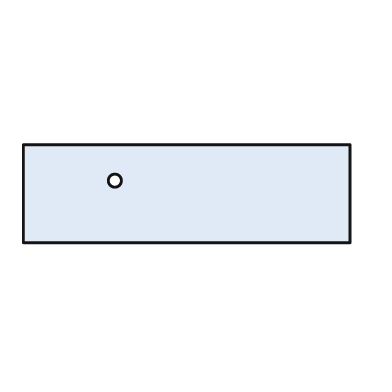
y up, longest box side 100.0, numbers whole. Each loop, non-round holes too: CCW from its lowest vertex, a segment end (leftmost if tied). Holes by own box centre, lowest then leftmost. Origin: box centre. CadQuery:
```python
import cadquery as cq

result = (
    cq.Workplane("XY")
    .moveTo(-50.0, -15.0)
    .lineTo(50.0, -15.0)
    .lineTo(50.0, 15.0)
    .lineTo(-50.0, 15.0)
    .close()
    .moveTo(-22.0, 4.0)
    .circle(2.0)
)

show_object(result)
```